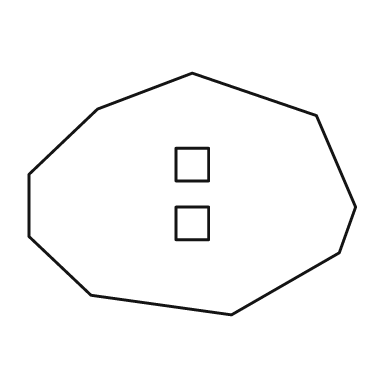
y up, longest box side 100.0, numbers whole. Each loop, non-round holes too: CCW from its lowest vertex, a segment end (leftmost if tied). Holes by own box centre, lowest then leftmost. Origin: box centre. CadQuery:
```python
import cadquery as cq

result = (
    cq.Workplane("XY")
    .moveTo(12.0, -37.0)
    .lineTo(45.0, -18.0)
    .lineTo(50.0, -4.0)
    .lineTo(38.0, 24.0)
    .lineTo(0.0, 37.0)
    .lineTo(-29.0, 26.0)
    .lineTo(-50.0, 6.0)
    .lineTo(-50.0, -13.0)
    .lineTo(-31.0, -31.0)
    .close()
    .moveTo(-5.0, -14.0)
    .lineTo(5.0, -14.0)
    .lineTo(5.0, -4.0)
    .lineTo(-5.0, -4.0)
    .close()
    .moveTo(-5.0, 4.0)
    .lineTo(5.0, 4.0)
    .lineTo(5.0, 14.0)
    .lineTo(-5.0, 14.0)
    .close()
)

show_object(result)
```